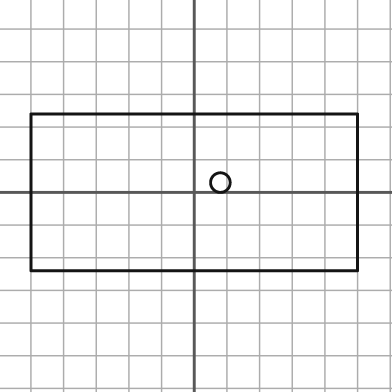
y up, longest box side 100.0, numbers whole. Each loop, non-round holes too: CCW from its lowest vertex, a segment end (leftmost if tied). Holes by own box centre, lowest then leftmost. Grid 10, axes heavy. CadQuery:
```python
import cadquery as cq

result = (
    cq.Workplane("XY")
    .moveTo(-50.0, -24.0)
    .lineTo(50.0, -24.0)
    .lineTo(50.0, 24.0)
    .lineTo(-50.0, 24.0)
    .close()
    .moveTo(8.0, 3.0)
    .circle(3.0)
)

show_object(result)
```